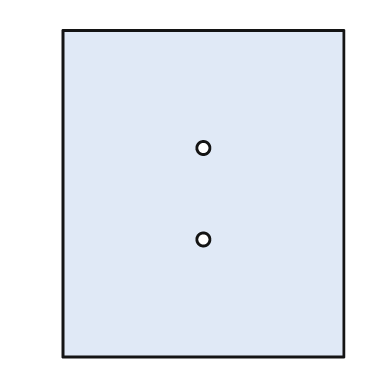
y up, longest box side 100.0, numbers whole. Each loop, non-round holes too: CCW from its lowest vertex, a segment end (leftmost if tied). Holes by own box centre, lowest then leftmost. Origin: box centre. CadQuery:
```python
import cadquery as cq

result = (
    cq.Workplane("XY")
    .moveTo(-43.0, -50.0)
    .lineTo(43.0, -50.0)
    .lineTo(43.0, 50.0)
    .lineTo(-43.0, 50.0)
    .close()
    .moveTo(0.0, -14.0)
    .circle(2.0)
    .moveTo(0.0, 14.0)
    .circle(2.0)
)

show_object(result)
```